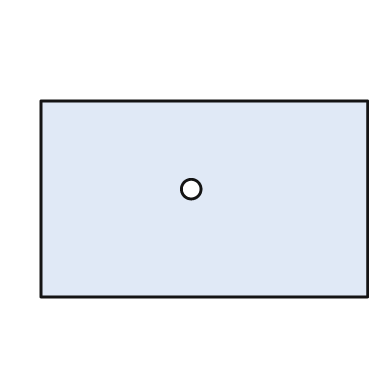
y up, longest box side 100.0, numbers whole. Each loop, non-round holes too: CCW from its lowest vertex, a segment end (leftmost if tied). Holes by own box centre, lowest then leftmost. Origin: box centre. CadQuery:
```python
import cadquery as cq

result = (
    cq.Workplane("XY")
    .moveTo(-50.0, -30.0)
    .lineTo(50.0, -30.0)
    .lineTo(50.0, 30.0)
    .lineTo(-50.0, 30.0)
    .close()
    .moveTo(-4.0, 3.0)
    .circle(3.0)
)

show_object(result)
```